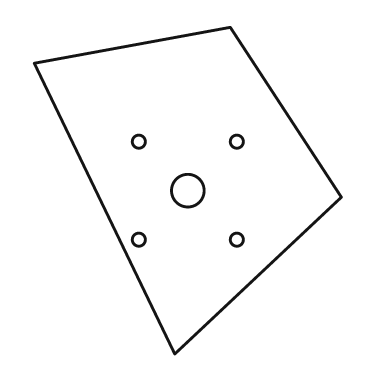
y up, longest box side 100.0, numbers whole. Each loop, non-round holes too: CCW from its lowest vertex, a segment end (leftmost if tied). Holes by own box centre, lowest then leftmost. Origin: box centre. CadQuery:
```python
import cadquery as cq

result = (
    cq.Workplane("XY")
    .moveTo(-4.0, -50.0)
    .lineTo(47.0, -2.0)
    .lineTo(13.0, 50.0)
    .lineTo(-47.0, 39.0)
    .close()
    .moveTo(-15.0, -15.0)
    .circle(2.0)
    .moveTo(15.0, -15.0)
    .circle(2.0)
    .moveTo(0.0, 0.0)
    .circle(5.0)
    .moveTo(-15.0, 15.0)
    .circle(2.0)
    .moveTo(15.0, 15.0)
    .circle(2.0)
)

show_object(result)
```